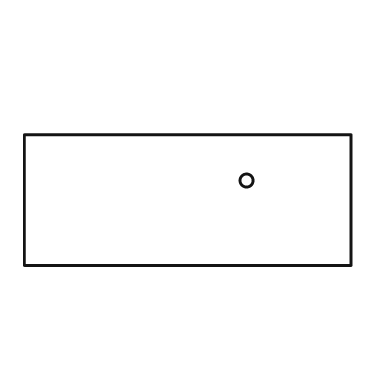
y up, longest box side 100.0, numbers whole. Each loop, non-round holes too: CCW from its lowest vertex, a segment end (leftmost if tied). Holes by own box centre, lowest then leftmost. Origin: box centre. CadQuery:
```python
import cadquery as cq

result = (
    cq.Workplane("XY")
    .moveTo(-50.0, -20.0)
    .lineTo(50.0, -20.0)
    .lineTo(50.0, 20.0)
    .lineTo(-50.0, 20.0)
    .close()
    .moveTo(18.0, 6.0)
    .circle(2.0)
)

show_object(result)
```